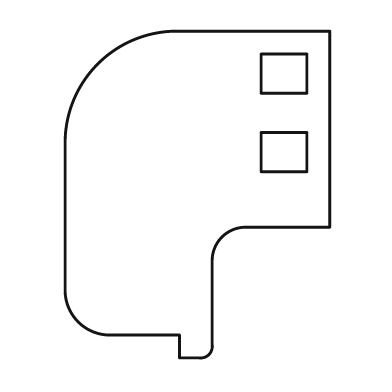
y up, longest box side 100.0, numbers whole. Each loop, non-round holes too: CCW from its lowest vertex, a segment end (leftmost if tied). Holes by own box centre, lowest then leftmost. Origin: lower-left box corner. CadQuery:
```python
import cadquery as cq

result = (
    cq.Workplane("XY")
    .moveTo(35.0, 0.0)
    .lineTo(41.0, 0.0)
    .threePointArc((44.0, 1.0), (45.0, 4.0))
    .lineTo(45.0, 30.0)
    .threePointArc((48.0, 37.0), (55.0, 40.0))
    .lineTo(81.0, 40.0)
    .lineTo(81.0, 100.0)
    .lineTo(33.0, 100.0)
    .threePointArc((10.0, 90.0), (0.0, 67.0))
    .lineTo(0.0, 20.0)
    .threePointArc((4.0, 11.0), (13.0, 7.0))
    .lineTo(35.0, 7.0)
    .close()
    .moveTo(60.0, 57.0)
    .lineTo(74.0, 57.0)
    .lineTo(74.0, 69.0)
    .lineTo(60.0, 69.0)
    .close()
    .moveTo(60.0, 81.0)
    .lineTo(74.0, 81.0)
    .lineTo(74.0, 93.0)
    .lineTo(60.0, 93.0)
    .close()
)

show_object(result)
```